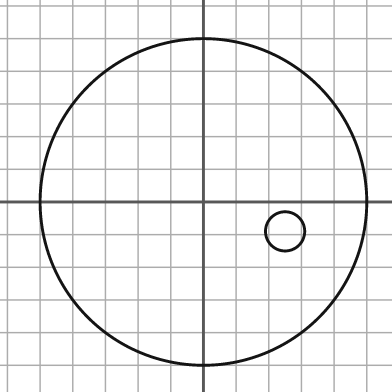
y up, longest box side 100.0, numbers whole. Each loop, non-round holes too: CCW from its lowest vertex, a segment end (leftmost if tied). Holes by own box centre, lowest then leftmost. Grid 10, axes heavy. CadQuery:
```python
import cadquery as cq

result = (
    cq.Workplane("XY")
    .moveTo(0.0, 0.0)
    .circle(50.0)
    .moveTo(25.0, -9.0)
    .circle(6.0)
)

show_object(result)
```